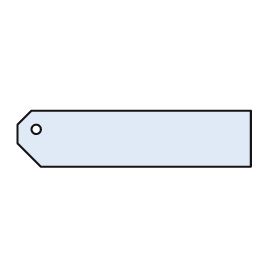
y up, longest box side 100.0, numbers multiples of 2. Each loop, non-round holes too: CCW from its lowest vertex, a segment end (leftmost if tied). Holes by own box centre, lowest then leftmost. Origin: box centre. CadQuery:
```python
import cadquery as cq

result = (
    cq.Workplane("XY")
    .moveTo(-40.0, -12.0)
    .lineTo(50.0, -12.0)
    .lineTo(50.0, 12.0)
    .lineTo(-44.0, 12.0)
    .lineTo(-50.0, 6.0)
    .lineTo(-50.0, -2.0)
    .close()
    .moveTo(-42.0, 4.0)
    .circle(2.0)
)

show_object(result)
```